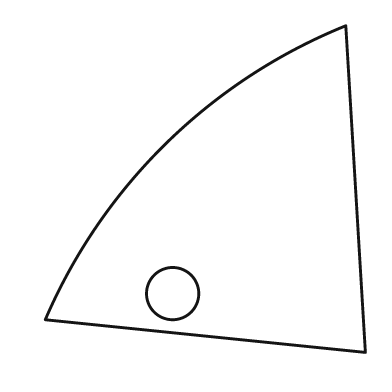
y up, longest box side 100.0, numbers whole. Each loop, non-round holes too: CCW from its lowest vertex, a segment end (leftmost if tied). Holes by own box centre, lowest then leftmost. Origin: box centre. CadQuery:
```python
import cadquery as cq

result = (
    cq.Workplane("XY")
    .moveTo(49.0, -50.0)
    .lineTo(43.0, 50.0)
    .threePointArc((-12.0, 14.0), (-49.0, -40.0))
    .close()
    .moveTo(-10.0, -32.0)
    .circle(8.0)
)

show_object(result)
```